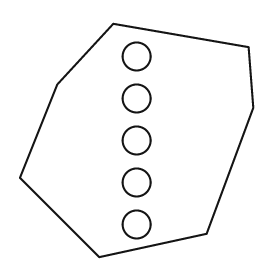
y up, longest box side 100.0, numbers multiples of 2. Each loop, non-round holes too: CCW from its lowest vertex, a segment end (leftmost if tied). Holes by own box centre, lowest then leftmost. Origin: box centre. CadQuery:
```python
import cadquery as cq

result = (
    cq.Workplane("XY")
    .moveTo(-16.0, -50.0)
    .lineTo(30.0, -40.0)
    .lineTo(50.0, 14.0)
    .lineTo(48.0, 40.0)
    .lineTo(-10.0, 50.0)
    .lineTo(-34.0, 24.0)
    .lineTo(-50.0, -16.0)
    .close()
    .moveTo(0.0, -36.0)
    .circle(6.0)
    .moveTo(0.0, -18.0)
    .circle(6.0)
    .moveTo(0.0, 0.0)
    .circle(6.0)
    .moveTo(0.0, 18.0)
    .circle(6.0)
    .moveTo(0.0, 36.0)
    .circle(6.0)
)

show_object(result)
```